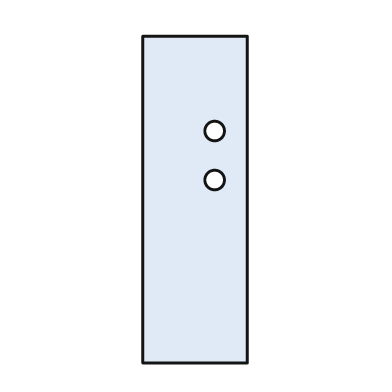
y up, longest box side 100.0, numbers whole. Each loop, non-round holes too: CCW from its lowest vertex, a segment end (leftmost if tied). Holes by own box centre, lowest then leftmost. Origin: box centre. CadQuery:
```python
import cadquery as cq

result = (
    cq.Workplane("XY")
    .moveTo(-16.0, -50.0)
    .lineTo(16.0, -50.0)
    .lineTo(16.0, 50.0)
    .lineTo(-16.0, 50.0)
    .close()
    .moveTo(6.0, 6.0)
    .circle(3.0)
    .moveTo(6.0, 21.0)
    .circle(3.0)
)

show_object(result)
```